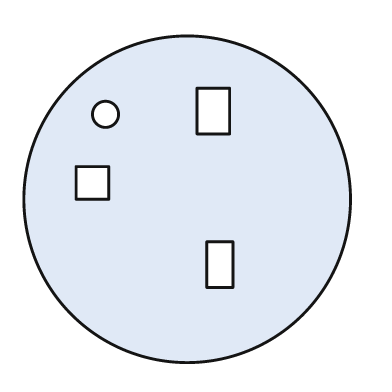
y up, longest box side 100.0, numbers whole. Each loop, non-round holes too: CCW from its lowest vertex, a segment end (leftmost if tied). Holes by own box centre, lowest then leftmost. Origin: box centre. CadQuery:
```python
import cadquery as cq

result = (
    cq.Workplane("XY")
    .moveTo(0.0, 0.0)
    .circle(50.0)
    .moveTo(6.0, -27.0)
    .lineTo(14.0, -27.0)
    .lineTo(14.0, -13.0)
    .lineTo(6.0, -13.0)
    .close()
    .moveTo(-34.0, 0.0)
    .lineTo(-24.0, 0.0)
    .lineTo(-24.0, 10.0)
    .lineTo(-34.0, 10.0)
    .close()
    .moveTo(-25.0, 26.0)
    .circle(4.0)
    .moveTo(3.0, 20.0)
    .lineTo(13.0, 20.0)
    .lineTo(13.0, 34.0)
    .lineTo(3.0, 34.0)
    .close()
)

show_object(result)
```